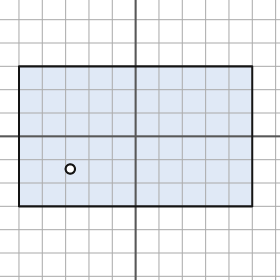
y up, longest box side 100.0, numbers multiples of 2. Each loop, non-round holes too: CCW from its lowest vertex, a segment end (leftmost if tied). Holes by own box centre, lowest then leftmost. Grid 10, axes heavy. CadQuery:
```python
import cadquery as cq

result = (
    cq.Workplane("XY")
    .moveTo(-50.0, -30.0)
    .lineTo(50.0, -30.0)
    .lineTo(50.0, 30.0)
    .lineTo(-50.0, 30.0)
    .close()
    .moveTo(-28.0, -14.0)
    .circle(2.0)
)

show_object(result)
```